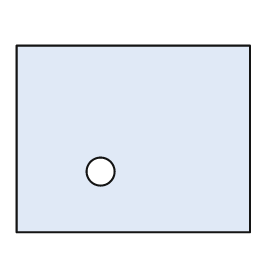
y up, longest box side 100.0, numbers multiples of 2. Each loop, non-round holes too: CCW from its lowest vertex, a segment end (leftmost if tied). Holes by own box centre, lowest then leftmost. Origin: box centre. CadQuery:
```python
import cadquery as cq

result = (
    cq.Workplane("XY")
    .moveTo(-50.0, -40.0)
    .lineTo(50.0, -40.0)
    .lineTo(50.0, 40.0)
    .lineTo(-50.0, 40.0)
    .close()
    .moveTo(-14.0, -14.0)
    .circle(6.0)
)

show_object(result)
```